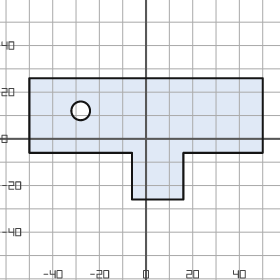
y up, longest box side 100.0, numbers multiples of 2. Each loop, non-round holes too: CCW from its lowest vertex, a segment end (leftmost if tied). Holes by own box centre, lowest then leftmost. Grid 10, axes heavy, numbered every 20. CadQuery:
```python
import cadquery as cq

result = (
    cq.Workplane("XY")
    .moveTo(-6.0, -26.0)
    .lineTo(16.0, -26.0)
    .lineTo(16.0, -6.0)
    .lineTo(50.0, -6.0)
    .lineTo(50.0, 26.0)
    .lineTo(-50.0, 26.0)
    .lineTo(-50.0, -6.0)
    .lineTo(-6.0, -6.0)
    .close()
    .moveTo(-28.0, 12.0)
    .circle(4.0)
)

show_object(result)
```